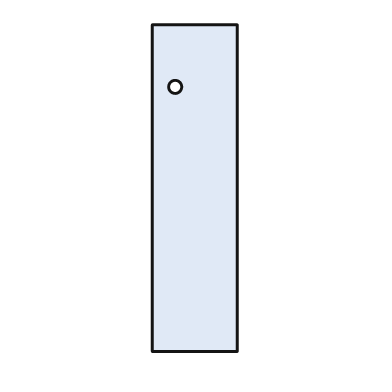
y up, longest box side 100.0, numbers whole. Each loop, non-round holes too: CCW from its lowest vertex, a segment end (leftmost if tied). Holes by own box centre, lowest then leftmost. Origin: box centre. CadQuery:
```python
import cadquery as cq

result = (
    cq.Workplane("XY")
    .moveTo(-13.0, -50.0)
    .lineTo(13.0, -50.0)
    .lineTo(13.0, 50.0)
    .lineTo(-13.0, 50.0)
    .close()
    .moveTo(-6.0, 31.0)
    .circle(2.0)
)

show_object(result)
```